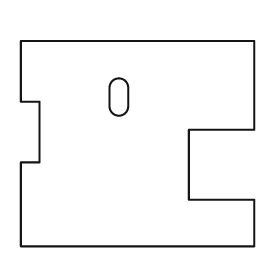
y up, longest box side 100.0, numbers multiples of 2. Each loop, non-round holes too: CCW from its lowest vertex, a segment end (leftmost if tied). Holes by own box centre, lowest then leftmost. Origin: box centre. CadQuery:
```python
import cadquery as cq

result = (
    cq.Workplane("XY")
    .moveTo(-50.0, -44.0)
    .lineTo(50.0, -44.0)
    .lineTo(50.0, -24.0)
    .lineTo(22.0, -24.0)
    .lineTo(22.0, 6.0)
    .lineTo(50.0, 6.0)
    .lineTo(50.0, 44.0)
    .lineTo(-50.0, 44.0)
    .lineTo(-50.0, 18.0)
    .lineTo(-42.0, 18.0)
    .lineTo(-42.0, -8.0)
    .lineTo(-50.0, -8.0)
    .close()
    .moveTo(-12.0, 16.0)
    .threePointArc((-8.0, 12.0), (-4.0, 16.0))
    .lineTo(-4.0, 24.0)
    .threePointArc((-8.0, 28.0), (-12.0, 24.0))
    .close()
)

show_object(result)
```